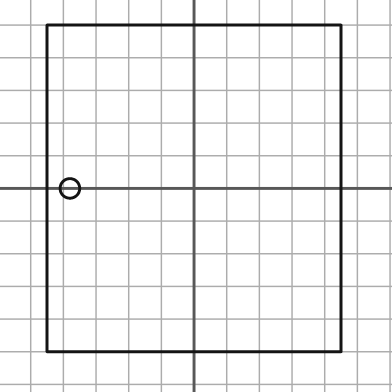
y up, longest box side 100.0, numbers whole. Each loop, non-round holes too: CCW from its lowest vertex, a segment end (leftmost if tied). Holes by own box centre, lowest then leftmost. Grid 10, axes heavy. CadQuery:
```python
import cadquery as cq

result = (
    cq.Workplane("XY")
    .moveTo(-45.0, -50.0)
    .lineTo(45.0, -50.0)
    .lineTo(45.0, 50.0)
    .lineTo(-45.0, 50.0)
    .close()
    .moveTo(-38.0, 0.0)
    .circle(3.0)
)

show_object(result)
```